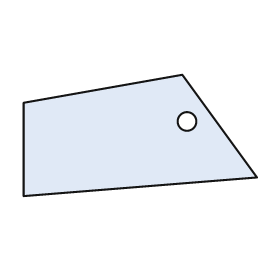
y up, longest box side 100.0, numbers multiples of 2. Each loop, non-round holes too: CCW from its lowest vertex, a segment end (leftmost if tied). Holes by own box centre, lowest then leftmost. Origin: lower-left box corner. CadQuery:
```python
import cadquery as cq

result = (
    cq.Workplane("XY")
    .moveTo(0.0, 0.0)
    .lineTo(100.0, 8.0)
    .lineTo(68.0, 52.0)
    .lineTo(0.0, 40.0)
    .close()
    .moveTo(70.0, 32.0)
    .circle(4.0)
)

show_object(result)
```